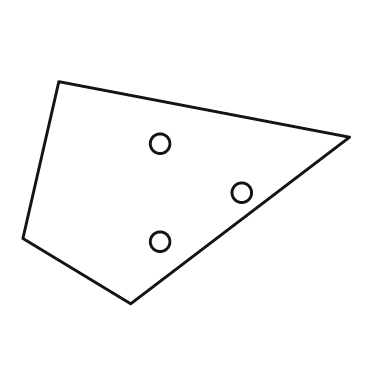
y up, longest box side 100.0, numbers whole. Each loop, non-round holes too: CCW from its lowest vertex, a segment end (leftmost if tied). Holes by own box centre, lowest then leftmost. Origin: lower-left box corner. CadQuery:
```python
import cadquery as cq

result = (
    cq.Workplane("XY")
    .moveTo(33.0, 0.0)
    .lineTo(100.0, 51.0)
    .lineTo(11.0, 68.0)
    .lineTo(0.0, 20.0)
    .close()
    .moveTo(42.0, 19.0)
    .circle(3.0)
    .moveTo(67.0, 34.0)
    .circle(3.0)
    .moveTo(42.0, 49.0)
    .circle(3.0)
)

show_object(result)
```